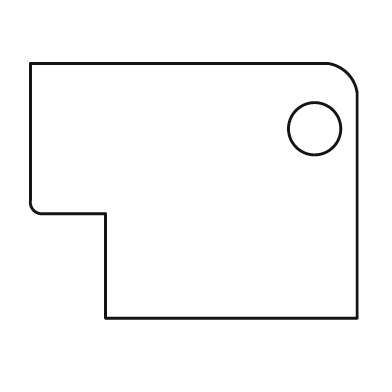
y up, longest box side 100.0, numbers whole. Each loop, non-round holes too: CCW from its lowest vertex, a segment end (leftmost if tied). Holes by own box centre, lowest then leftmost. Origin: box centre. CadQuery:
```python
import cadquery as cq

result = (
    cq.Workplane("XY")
    .moveTo(-27.0, -39.0)
    .lineTo(50.0, -39.0)
    .lineTo(50.0, 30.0)
    .threePointArc((47.0, 36.0), (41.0, 39.0))
    .lineTo(-50.0, 39.0)
    .lineTo(-50.0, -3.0)
    .threePointArc((-49.0, -6.0), (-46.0, -7.0))
    .lineTo(-27.0, -7.0)
    .close()
    .moveTo(37.0, 19.0)
    .circle(8.0)
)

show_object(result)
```